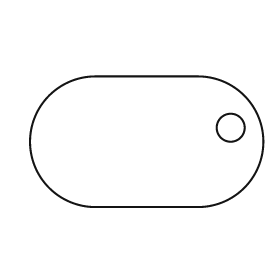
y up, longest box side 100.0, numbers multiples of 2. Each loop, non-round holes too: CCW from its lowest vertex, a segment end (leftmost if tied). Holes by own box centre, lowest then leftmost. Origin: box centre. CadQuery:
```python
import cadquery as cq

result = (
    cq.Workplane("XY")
    .moveTo(-22.0, -28.0)
    .lineTo(22.0, -28.0)
    .threePointArc((50.0, 0.0), (22.0, 28.0))
    .lineTo(-22.0, 28.0)
    .threePointArc((-50.0, 0.0), (-22.0, -28.0))
    .close()
    .moveTo(36.0, 6.0)
    .circle(6.0)
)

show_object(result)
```